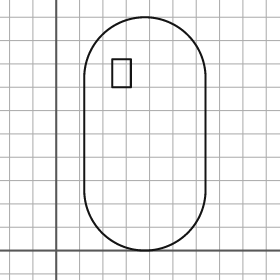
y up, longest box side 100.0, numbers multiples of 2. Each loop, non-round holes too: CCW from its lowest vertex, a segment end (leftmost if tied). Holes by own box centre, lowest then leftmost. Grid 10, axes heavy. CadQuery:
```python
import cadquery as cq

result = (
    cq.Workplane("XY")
    .moveTo(12.0, 26.0)
    .threePointArc((38.0, 0.0), (64.0, 26.0))
    .lineTo(64.0, 74.0)
    .threePointArc((38.0, 100.0), (12.0, 74.0))
    .close()
    .moveTo(24.0, 70.0)
    .lineTo(32.0, 70.0)
    .lineTo(32.0, 82.0)
    .lineTo(24.0, 82.0)
    .close()
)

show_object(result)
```